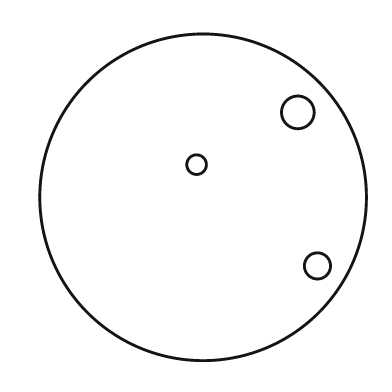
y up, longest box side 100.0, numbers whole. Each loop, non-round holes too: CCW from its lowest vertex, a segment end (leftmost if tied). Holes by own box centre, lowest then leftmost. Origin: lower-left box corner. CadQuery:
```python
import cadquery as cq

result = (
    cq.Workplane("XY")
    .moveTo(50.0, 50.0)
    .circle(50.0)
    .moveTo(85.0, 29.0)
    .circle(4.0)
    .moveTo(48.0, 60.0)
    .circle(3.0)
    .moveTo(79.0, 76.0)
    .circle(5.0)
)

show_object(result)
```